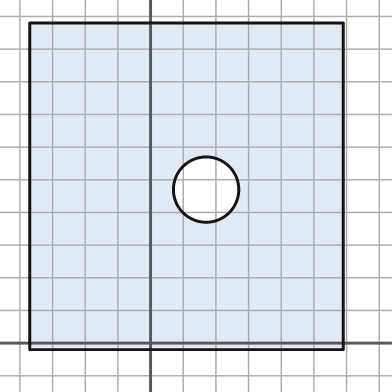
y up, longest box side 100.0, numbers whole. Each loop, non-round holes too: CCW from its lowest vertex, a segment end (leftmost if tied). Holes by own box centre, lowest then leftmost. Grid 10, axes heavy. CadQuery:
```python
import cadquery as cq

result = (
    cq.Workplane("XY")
    .moveTo(-37.0, -2.0)
    .lineTo(59.0, -2.0)
    .lineTo(59.0, 98.0)
    .lineTo(-37.0, 98.0)
    .close()
    .moveTo(17.0, 47.0)
    .circle(10.0)
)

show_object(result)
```